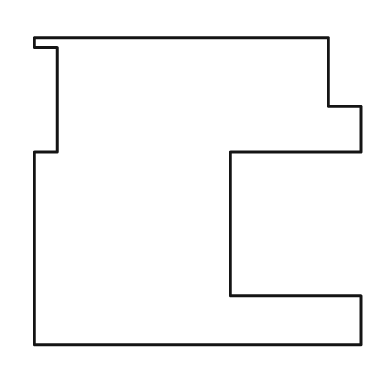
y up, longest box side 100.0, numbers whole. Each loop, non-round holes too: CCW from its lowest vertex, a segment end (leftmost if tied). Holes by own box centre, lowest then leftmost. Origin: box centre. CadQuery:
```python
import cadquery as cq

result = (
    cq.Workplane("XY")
    .moveTo(-50.0, -47.0)
    .lineTo(50.0, -47.0)
    .lineTo(50.0, -32.0)
    .lineTo(10.0, -32.0)
    .lineTo(10.0, 12.0)
    .lineTo(50.0, 12.0)
    .lineTo(50.0, 26.0)
    .lineTo(40.0, 26.0)
    .lineTo(40.0, 47.0)
    .lineTo(-50.0, 47.0)
    .lineTo(-50.0, 44.0)
    .lineTo(-43.0, 44.0)
    .lineTo(-43.0, 12.0)
    .lineTo(-50.0, 12.0)
    .close()
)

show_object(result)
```